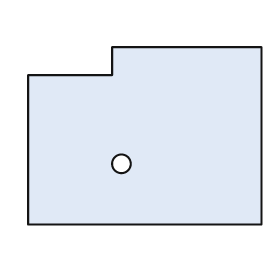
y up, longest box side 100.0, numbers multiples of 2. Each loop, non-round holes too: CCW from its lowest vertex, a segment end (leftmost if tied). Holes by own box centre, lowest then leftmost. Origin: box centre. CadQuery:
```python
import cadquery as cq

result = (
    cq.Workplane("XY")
    .moveTo(-50.0, -38.0)
    .lineTo(50.0, -38.0)
    .lineTo(50.0, 38.0)
    .lineTo(-14.0, 38.0)
    .lineTo(-14.0, 26.0)
    .lineTo(-50.0, 26.0)
    .close()
    .moveTo(-10.0, -12.0)
    .circle(4.0)
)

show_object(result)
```